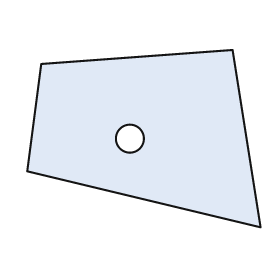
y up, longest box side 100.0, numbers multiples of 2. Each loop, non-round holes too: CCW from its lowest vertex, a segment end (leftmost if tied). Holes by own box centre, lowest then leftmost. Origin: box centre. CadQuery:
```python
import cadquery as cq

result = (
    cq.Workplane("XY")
    .moveTo(50.0, -38.0)
    .lineTo(38.0, 38.0)
    .lineTo(-44.0, 32.0)
    .lineTo(-50.0, -14.0)
    .close()
    .moveTo(-6.0, 0.0)
    .circle(6.0)
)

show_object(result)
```